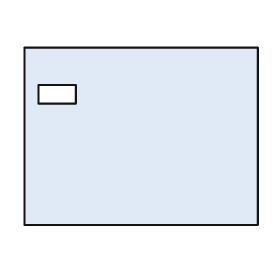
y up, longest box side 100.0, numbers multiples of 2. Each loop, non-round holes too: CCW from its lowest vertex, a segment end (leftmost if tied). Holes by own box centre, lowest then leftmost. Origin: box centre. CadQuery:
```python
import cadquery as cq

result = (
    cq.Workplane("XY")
    .moveTo(-50.0, -38.0)
    .lineTo(50.0, -38.0)
    .lineTo(50.0, 38.0)
    .lineTo(-50.0, 38.0)
    .close()
    .moveTo(-44.0, 14.0)
    .lineTo(-28.0, 14.0)
    .lineTo(-28.0, 22.0)
    .lineTo(-44.0, 22.0)
    .close()
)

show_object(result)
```